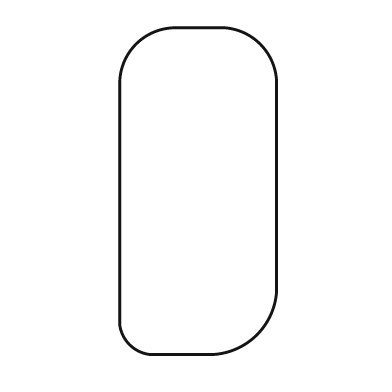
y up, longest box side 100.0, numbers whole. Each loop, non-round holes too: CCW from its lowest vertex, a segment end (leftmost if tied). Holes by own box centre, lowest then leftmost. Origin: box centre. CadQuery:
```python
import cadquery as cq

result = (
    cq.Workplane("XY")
    .moveTo(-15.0, -50.0)
    .lineTo(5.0, -50.0)
    .threePointArc((18.0, -44.0), (24.0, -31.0))
    .lineTo(24.0, 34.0)
    .threePointArc((19.0, 45.0), (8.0, 50.0))
    .lineTo(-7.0, 50.0)
    .threePointArc((-19.0, 45.0), (-24.0, 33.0))
    .lineTo(-24.0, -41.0)
    .threePointArc((-21.0, -47.0), (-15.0, -50.0))
    .close()
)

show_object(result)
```